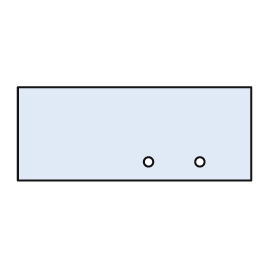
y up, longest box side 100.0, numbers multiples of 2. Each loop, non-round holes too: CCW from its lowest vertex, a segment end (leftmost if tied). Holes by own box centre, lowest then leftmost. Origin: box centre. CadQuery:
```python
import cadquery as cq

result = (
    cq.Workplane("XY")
    .moveTo(-50.0, -20.0)
    .lineTo(50.0, -20.0)
    .lineTo(50.0, 20.0)
    .lineTo(-50.0, 20.0)
    .close()
    .moveTo(6.0, -12.0)
    .circle(2.0)
    .moveTo(28.0, -12.0)
    .circle(2.0)
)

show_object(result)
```